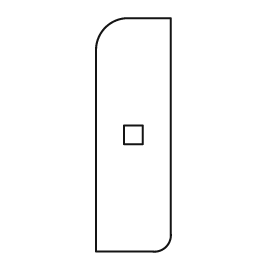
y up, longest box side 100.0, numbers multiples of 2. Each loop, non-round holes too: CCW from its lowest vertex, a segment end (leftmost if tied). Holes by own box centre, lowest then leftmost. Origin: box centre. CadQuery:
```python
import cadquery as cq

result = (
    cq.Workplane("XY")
    .moveTo(-16.0, -50.0)
    .lineTo(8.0, -50.0)
    .threePointArc((14.0, -48.0), (16.0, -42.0))
    .lineTo(16.0, 50.0)
    .lineTo(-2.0, 50.0)
    .threePointArc((-12.0, 46.0), (-16.0, 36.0))
    .close()
    .moveTo(-4.0, -4.0)
    .lineTo(4.0, -4.0)
    .lineTo(4.0, 4.0)
    .lineTo(-4.0, 4.0)
    .close()
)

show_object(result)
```